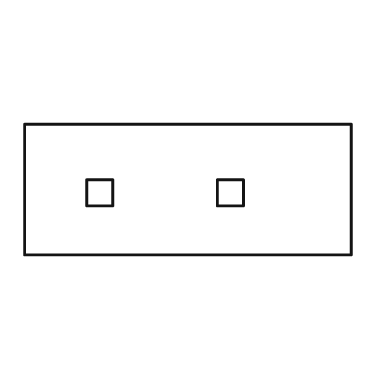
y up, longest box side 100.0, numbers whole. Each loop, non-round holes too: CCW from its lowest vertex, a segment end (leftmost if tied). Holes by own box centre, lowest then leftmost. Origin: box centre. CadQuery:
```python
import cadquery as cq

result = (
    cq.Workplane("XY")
    .moveTo(-50.0, -20.0)
    .lineTo(50.0, -20.0)
    .lineTo(50.0, 20.0)
    .lineTo(-50.0, 20.0)
    .close()
    .moveTo(-31.0, -5.0)
    .lineTo(-23.0, -5.0)
    .lineTo(-23.0, 3.0)
    .lineTo(-31.0, 3.0)
    .close()
    .moveTo(9.0, -5.0)
    .lineTo(17.0, -5.0)
    .lineTo(17.0, 3.0)
    .lineTo(9.0, 3.0)
    .close()
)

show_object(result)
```